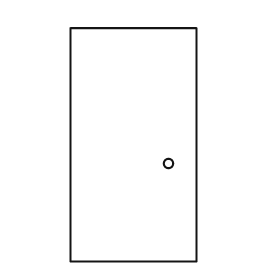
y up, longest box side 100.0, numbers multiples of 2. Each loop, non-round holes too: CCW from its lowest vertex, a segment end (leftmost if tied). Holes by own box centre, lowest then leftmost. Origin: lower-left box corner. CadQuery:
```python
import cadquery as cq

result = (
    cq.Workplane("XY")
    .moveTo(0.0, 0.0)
    .lineTo(54.0, 0.0)
    .lineTo(54.0, 100.0)
    .lineTo(0.0, 100.0)
    .close()
    .moveTo(42.0, 42.0)
    .circle(2.0)
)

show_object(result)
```